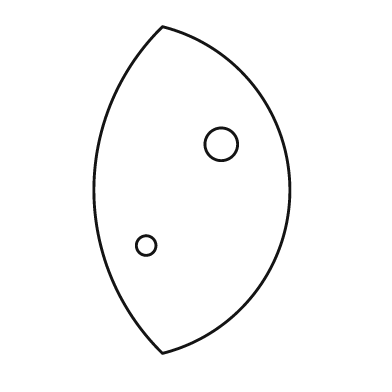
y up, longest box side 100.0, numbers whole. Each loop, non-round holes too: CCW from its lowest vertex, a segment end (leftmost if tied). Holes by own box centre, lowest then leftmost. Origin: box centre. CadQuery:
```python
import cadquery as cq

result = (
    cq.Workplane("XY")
    .moveTo(-9.0, -50.0)
    .threePointArc((30.0, 0.0), (-9.0, 50.0))
    .threePointArc((-30.0, 0.0), (-9.0, -50.0))
    .close()
    .moveTo(-14.0, -17.0)
    .circle(3.0)
    .moveTo(9.0, 14.0)
    .circle(5.0)
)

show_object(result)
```